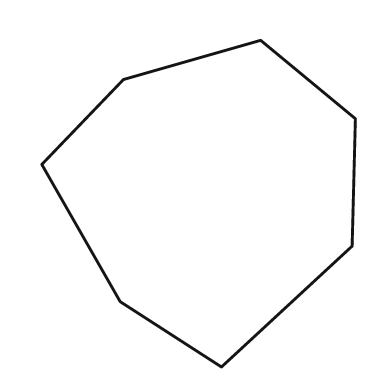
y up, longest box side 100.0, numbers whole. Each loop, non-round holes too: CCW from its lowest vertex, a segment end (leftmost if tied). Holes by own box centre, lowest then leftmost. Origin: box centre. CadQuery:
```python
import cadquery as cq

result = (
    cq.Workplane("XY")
    .moveTo(7.0, -50.0)
    .lineTo(47.0, -13.0)
    .lineTo(48.0, 26.0)
    .lineTo(19.0, 50.0)
    .lineTo(-23.0, 38.0)
    .lineTo(-48.0, 12.0)
    .lineTo(-24.0, -30.0)
    .close()
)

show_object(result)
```